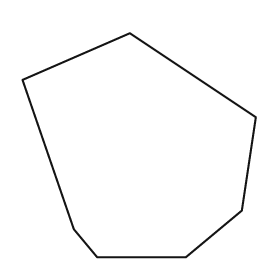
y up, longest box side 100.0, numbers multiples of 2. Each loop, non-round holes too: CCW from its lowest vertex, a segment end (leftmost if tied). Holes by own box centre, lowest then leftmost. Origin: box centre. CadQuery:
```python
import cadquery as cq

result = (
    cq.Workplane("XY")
    .moveTo(-18.0, -48.0)
    .lineTo(20.0, -48.0)
    .lineTo(44.0, -28.0)
    .lineTo(50.0, 12.0)
    .lineTo(-4.0, 48.0)
    .lineTo(-50.0, 28.0)
    .lineTo(-28.0, -36.0)
    .close()
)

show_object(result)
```